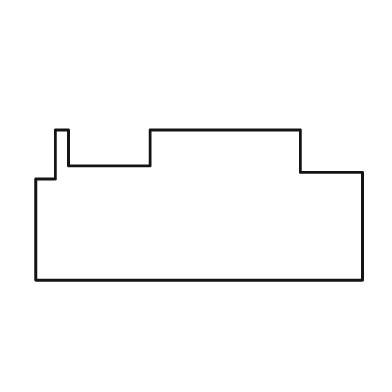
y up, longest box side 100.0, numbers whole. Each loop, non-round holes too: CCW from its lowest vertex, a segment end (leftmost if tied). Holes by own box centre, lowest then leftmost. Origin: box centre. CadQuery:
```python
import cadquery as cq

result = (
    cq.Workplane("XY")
    .moveTo(-50.0, -23.0)
    .lineTo(50.0, -23.0)
    .lineTo(50.0, 10.0)
    .lineTo(31.0, 10.0)
    .lineTo(31.0, 23.0)
    .lineTo(-15.0, 23.0)
    .lineTo(-15.0, 12.0)
    .lineTo(-40.0, 12.0)
    .lineTo(-40.0, 23.0)
    .lineTo(-44.0, 23.0)
    .lineTo(-44.0, 8.0)
    .lineTo(-50.0, 8.0)
    .close()
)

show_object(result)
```